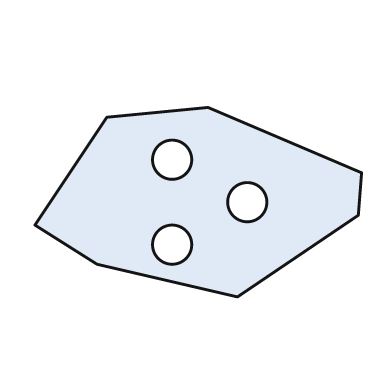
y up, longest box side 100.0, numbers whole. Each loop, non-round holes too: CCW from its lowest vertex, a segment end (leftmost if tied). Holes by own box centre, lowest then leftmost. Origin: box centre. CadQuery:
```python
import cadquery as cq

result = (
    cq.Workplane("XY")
    .moveTo(12.0, -29.0)
    .lineTo(49.0, -4.0)
    .lineTo(50.0, 9.0)
    .lineTo(3.0, 29.0)
    .lineTo(-28.0, 26.0)
    .lineTo(-50.0, -7.0)
    .lineTo(-31.0, -19.0)
    .close()
    .moveTo(-8.0, -13.0)
    .circle(6.0)
    .moveTo(15.0, 0.0)
    .circle(6.0)
    .moveTo(-8.0, 13.0)
    .circle(6.0)
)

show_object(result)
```